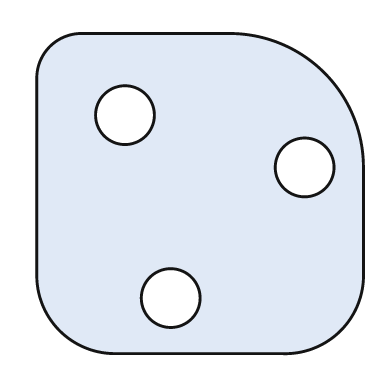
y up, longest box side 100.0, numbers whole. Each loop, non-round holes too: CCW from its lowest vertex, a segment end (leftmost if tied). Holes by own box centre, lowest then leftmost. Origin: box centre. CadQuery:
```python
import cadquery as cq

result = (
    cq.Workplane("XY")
    .moveTo(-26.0, -49.0)
    .lineTo(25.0, -49.0)
    .threePointArc((43.0, -42.0), (50.0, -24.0))
    .lineTo(50.0, 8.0)
    .threePointArc((38.0, 37.0), (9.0, 49.0))
    .lineTo(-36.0, 49.0)
    .threePointArc((-46.0, 45.0), (-50.0, 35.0))
    .lineTo(-50.0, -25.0)
    .threePointArc((-43.0, -42.0), (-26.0, -49.0))
    .close()
    .moveTo(-9.0, -32.0)
    .circle(9.0)
    .moveTo(32.0, 8.0)
    .circle(9.0)
    .moveTo(-23.0, 24.0)
    .circle(9.0)
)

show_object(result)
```